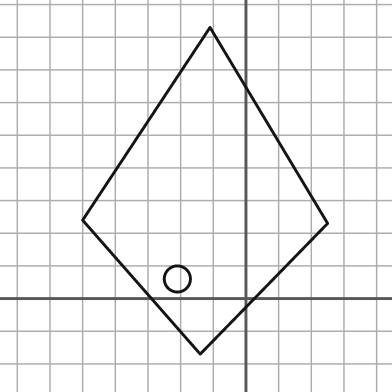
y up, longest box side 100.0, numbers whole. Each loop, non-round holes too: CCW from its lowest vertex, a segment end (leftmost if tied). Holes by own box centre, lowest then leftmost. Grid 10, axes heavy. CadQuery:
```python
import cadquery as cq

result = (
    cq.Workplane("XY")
    .moveTo(-14.0, -17.0)
    .lineTo(25.0, 23.0)
    .lineTo(-11.0, 83.0)
    .lineTo(-50.0, 24.0)
    .close()
    .moveTo(-21.0, 6.0)
    .circle(4.0)
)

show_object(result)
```